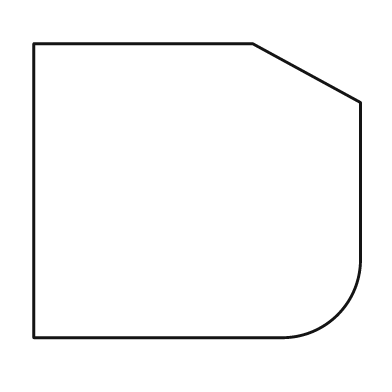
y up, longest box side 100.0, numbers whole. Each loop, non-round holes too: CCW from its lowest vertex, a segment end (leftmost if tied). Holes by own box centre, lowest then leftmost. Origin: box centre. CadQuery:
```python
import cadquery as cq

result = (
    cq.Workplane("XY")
    .moveTo(-50.0, -45.0)
    .lineTo(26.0, -45.0)
    .threePointArc((43.0, -38.0), (50.0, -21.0))
    .lineTo(50.0, 27.0)
    .lineTo(17.0, 45.0)
    .lineTo(-50.0, 45.0)
    .close()
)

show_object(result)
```